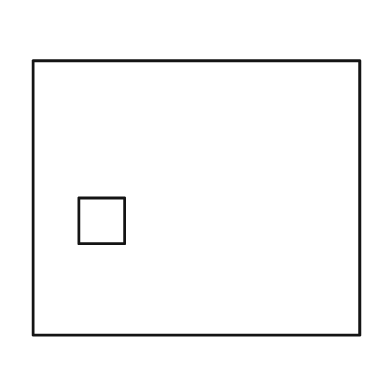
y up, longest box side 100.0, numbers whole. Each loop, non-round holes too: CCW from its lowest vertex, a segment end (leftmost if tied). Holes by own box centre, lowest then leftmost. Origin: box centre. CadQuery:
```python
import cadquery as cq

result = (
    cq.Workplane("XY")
    .moveTo(-50.0, -42.0)
    .lineTo(50.0, -42.0)
    .lineTo(50.0, 42.0)
    .lineTo(-50.0, 42.0)
    .close()
    .moveTo(-36.0, -14.0)
    .lineTo(-22.0, -14.0)
    .lineTo(-22.0, 0.0)
    .lineTo(-36.0, 0.0)
    .close()
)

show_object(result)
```